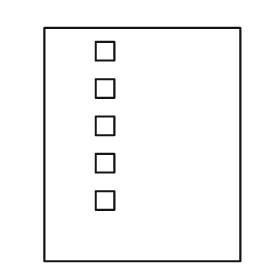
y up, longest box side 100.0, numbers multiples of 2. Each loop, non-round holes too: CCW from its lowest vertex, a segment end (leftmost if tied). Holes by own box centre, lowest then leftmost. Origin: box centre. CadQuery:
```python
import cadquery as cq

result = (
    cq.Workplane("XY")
    .moveTo(-42.0, -50.0)
    .lineTo(42.0, -50.0)
    .lineTo(42.0, 50.0)
    .lineTo(-42.0, 50.0)
    .close()
    .moveTo(-20.0, -28.0)
    .lineTo(-12.0, -28.0)
    .lineTo(-12.0, -20.0)
    .lineTo(-20.0, -20.0)
    .close()
    .moveTo(-20.0, -12.0)
    .lineTo(-12.0, -12.0)
    .lineTo(-12.0, -4.0)
    .lineTo(-20.0, -4.0)
    .close()
    .moveTo(-20.0, 4.0)
    .lineTo(-12.0, 4.0)
    .lineTo(-12.0, 12.0)
    .lineTo(-20.0, 12.0)
    .close()
    .moveTo(-20.0, 20.0)
    .lineTo(-12.0, 20.0)
    .lineTo(-12.0, 28.0)
    .lineTo(-20.0, 28.0)
    .close()
    .moveTo(-20.0, 36.0)
    .lineTo(-12.0, 36.0)
    .lineTo(-12.0, 44.0)
    .lineTo(-20.0, 44.0)
    .close()
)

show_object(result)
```